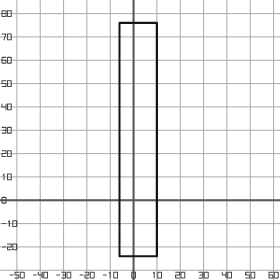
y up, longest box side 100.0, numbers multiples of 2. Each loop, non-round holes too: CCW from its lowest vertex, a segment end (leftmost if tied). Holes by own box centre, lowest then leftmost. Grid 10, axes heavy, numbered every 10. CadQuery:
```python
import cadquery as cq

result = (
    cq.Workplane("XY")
    .moveTo(-6.0, -24.0)
    .lineTo(10.0, -24.0)
    .lineTo(10.0, 76.0)
    .lineTo(-6.0, 76.0)
    .close()
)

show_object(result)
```